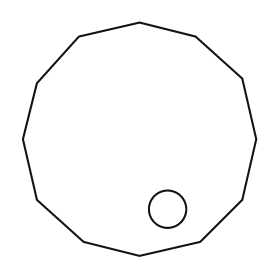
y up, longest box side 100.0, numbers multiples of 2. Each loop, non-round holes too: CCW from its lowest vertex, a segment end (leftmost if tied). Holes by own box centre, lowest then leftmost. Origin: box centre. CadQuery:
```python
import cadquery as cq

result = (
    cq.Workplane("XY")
    .moveTo(0.0, -50.0)
    .lineTo(26.0, -44.0)
    .lineTo(44.0, -26.0)
    .lineTo(50.0, 0.0)
    .lineTo(44.0, 26.0)
    .lineTo(24.0, 44.0)
    .lineTo(0.0, 50.0)
    .lineTo(-26.0, 44.0)
    .lineTo(-44.0, 24.0)
    .lineTo(-50.0, 0.0)
    .lineTo(-44.0, -26.0)
    .lineTo(-24.0, -44.0)
    .close()
    .moveTo(12.0, -30.0)
    .circle(8.0)
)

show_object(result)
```